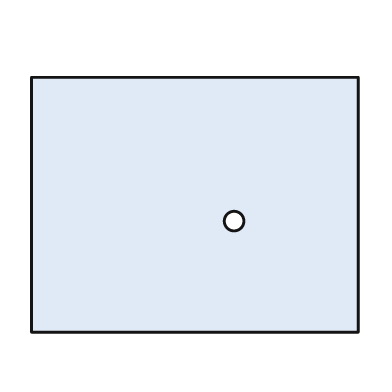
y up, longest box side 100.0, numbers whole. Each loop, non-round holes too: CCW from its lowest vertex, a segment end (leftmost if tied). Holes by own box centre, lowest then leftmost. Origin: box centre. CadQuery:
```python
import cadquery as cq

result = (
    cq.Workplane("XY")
    .moveTo(-50.0, -39.0)
    .lineTo(50.0, -39.0)
    .lineTo(50.0, 39.0)
    .lineTo(-50.0, 39.0)
    .close()
    .moveTo(12.0, -5.0)
    .circle(3.0)
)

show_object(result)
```